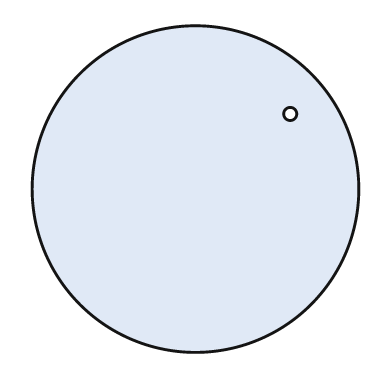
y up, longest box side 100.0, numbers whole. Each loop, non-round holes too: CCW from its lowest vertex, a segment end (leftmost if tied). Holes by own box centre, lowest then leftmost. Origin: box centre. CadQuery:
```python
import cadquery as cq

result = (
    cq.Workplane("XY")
    .moveTo(0.0, 0.0)
    .circle(50.0)
    .moveTo(29.0, 23.0)
    .circle(2.0)
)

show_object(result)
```